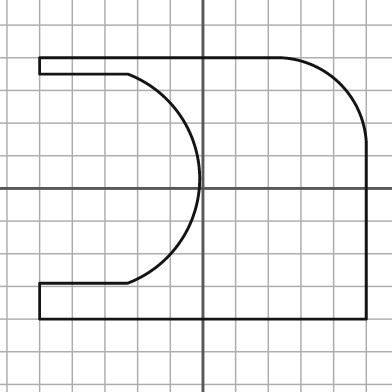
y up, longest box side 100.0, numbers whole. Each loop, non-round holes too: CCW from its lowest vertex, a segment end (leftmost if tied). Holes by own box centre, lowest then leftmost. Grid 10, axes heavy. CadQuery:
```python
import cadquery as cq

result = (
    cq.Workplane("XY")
    .moveTo(-50.0, -40.0)
    .lineTo(50.0, -40.0)
    .lineTo(50.0, 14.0)
    .threePointArc((42.0, 32.0), (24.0, 40.0))
    .lineTo(-50.0, 40.0)
    .lineTo(-50.0, 35.0)
    .lineTo(-23.0, 35.0)
    .threePointArc((-1.0, 3.0), (-23.0, -29.0))
    .lineTo(-50.0, -29.0)
    .close()
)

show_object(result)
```